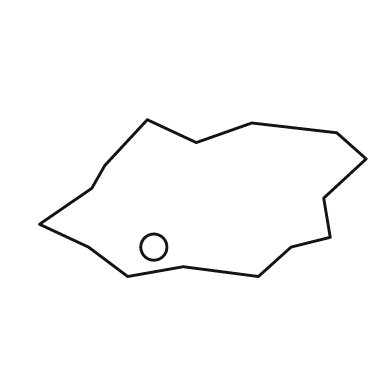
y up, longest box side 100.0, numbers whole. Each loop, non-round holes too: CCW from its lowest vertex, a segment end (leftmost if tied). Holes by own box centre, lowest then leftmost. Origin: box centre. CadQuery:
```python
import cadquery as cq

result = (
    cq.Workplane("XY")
    .moveTo(-23.0, -24.0)
    .lineTo(-6.0, -21.0)
    .lineTo(17.0, -24.0)
    .lineTo(27.0, -15.0)
    .lineTo(39.0, -12.0)
    .lineTo(37.0, 0.0)
    .lineTo(50.0, 12.0)
    .lineTo(41.0, 20.0)
    .lineTo(15.0, 23.0)
    .lineTo(-2.0, 17.0)
    .lineTo(-17.0, 24.0)
    .lineTo(-30.0, 10.0)
    .lineTo(-34.0, 3.0)
    .lineTo(-50.0, -8.0)
    .lineTo(-35.0, -15.0)
    .close()
    .moveTo(-15.0, -15.0)
    .circle(4.0)
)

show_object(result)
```